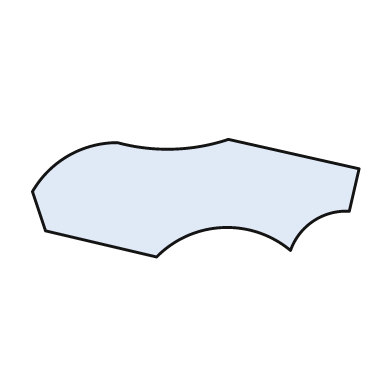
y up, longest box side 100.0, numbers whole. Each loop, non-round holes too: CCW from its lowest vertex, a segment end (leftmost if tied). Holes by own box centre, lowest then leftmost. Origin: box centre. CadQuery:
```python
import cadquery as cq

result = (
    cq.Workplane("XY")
    .moveTo(-12.0, -18.0)
    .threePointArc((8.0, -9.0), (29.0, -16.0))
    .threePointArc((36.0, -7.0), (47.0, -4.0))
    .lineTo(50.0, 9.0)
    .lineTo(10.0, 18.0)
    .threePointArc((-7.0, 15.0), (-24.0, 17.0))
    .threePointArc((-39.0, 13.0), (-50.0, 2.0))
    .lineTo(-46.0, -10.0)
    .close()
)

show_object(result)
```